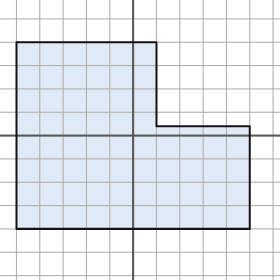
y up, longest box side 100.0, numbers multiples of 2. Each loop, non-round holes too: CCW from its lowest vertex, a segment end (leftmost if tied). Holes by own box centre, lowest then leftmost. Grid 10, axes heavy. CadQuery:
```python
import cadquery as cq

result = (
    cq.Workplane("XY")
    .moveTo(-50.0, -40.0)
    .lineTo(50.0, -40.0)
    .lineTo(50.0, 4.0)
    .lineTo(10.0, 4.0)
    .lineTo(10.0, 40.0)
    .lineTo(-50.0, 40.0)
    .close()
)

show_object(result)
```